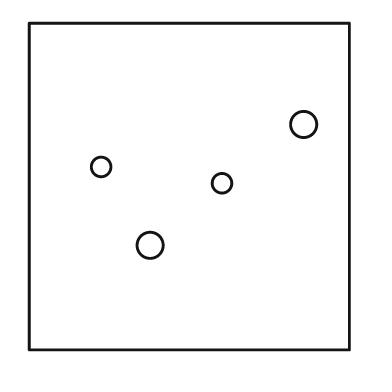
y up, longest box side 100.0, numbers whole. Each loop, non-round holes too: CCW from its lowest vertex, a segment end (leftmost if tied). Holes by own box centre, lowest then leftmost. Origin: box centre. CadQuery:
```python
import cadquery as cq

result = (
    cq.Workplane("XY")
    .moveTo(-49.0, -50.0)
    .lineTo(49.0, -50.0)
    .lineTo(49.0, 50.0)
    .lineTo(-49.0, 50.0)
    .close()
    .moveTo(-12.0, -18.0)
    .circle(4.0)
    .moveTo(10.0, 1.0)
    .circle(3.0)
    .moveTo(-27.0, 6.0)
    .circle(3.0)
    .moveTo(35.0, 19.0)
    .circle(4.0)
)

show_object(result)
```